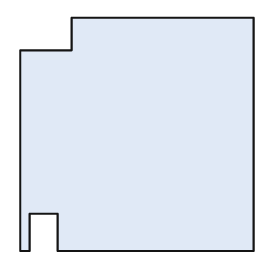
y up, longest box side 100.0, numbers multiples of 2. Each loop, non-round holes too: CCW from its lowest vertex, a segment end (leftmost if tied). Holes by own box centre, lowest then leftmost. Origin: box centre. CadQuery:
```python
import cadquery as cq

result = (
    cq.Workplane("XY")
    .moveTo(-50.0, -50.0)
    .lineTo(-46.0, -50.0)
    .lineTo(-46.0, -34.0)
    .lineTo(-34.0, -34.0)
    .lineTo(-34.0, -50.0)
    .lineTo(50.0, -50.0)
    .lineTo(50.0, 50.0)
    .lineTo(-28.0, 50.0)
    .lineTo(-28.0, 36.0)
    .lineTo(-50.0, 36.0)
    .close()
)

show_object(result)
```